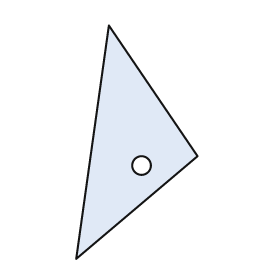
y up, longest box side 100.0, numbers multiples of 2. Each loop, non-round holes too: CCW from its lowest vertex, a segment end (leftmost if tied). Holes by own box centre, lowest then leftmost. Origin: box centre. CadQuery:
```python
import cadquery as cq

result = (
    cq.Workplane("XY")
    .moveTo(-26.0, -50.0)
    .lineTo(26.0, -6.0)
    .lineTo(-12.0, 50.0)
    .close()
    .moveTo(2.0, -10.0)
    .circle(4.0)
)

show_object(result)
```